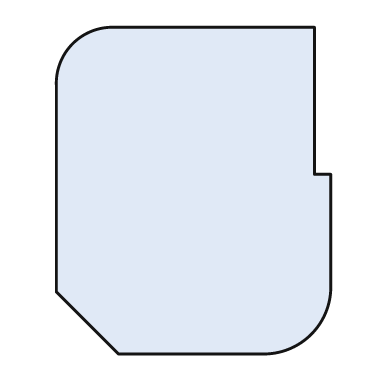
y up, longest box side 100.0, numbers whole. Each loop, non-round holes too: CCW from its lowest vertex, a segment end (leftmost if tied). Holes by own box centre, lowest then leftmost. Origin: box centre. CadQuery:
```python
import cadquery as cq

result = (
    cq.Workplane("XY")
    .moveTo(-23.0, -50.0)
    .lineTo(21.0, -50.0)
    .threePointArc((36.0, -44.0), (42.0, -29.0))
    .lineTo(42.0, 5.0)
    .lineTo(37.0, 5.0)
    .lineTo(37.0, 50.0)
    .lineTo(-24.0, 50.0)
    .threePointArc((-37.0, 45.0), (-42.0, 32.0))
    .lineTo(-42.0, -31.0)
    .close()
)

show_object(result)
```